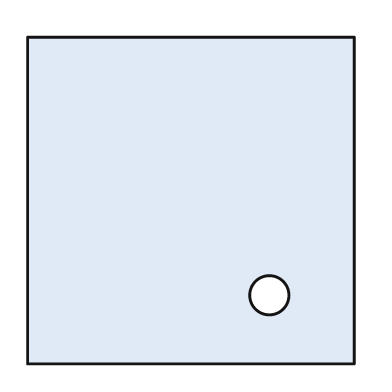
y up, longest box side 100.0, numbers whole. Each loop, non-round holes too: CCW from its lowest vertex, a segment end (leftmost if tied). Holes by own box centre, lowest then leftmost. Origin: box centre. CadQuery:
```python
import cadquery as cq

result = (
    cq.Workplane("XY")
    .moveTo(-50.0, -50.0)
    .lineTo(50.0, -50.0)
    .lineTo(50.0, 50.0)
    .lineTo(-50.0, 50.0)
    .close()
    .moveTo(24.0, -29.0)
    .circle(6.0)
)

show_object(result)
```